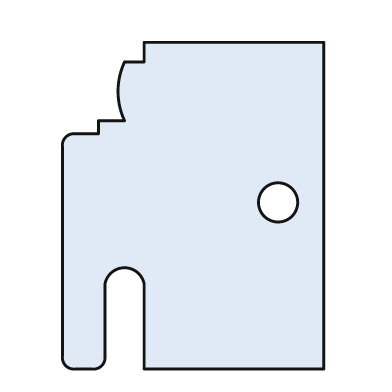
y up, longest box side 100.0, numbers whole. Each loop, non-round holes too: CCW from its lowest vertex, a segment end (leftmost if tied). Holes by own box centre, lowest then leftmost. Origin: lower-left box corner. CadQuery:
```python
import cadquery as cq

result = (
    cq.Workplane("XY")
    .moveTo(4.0, 0.0)
    .lineTo(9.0, 0.0)
    .threePointArc((12.0, 1.0), (13.0, 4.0))
    .lineTo(13.0, 26.0)
    .threePointArc((19.0, 31.0), (25.0, 26.0))
    .lineTo(25.0, 0.0)
    .lineTo(80.0, 0.0)
    .lineTo(80.0, 100.0)
    .lineTo(25.0, 100.0)
    .lineTo(25.0, 94.0)
    .lineTo(19.0, 94.0)
    .threePointArc((17.0, 85.0), (19.0, 76.0))
    .lineTo(11.0, 76.0)
    .lineTo(11.0, 72.0)
    .lineTo(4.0, 72.0)
    .threePointArc((1.0, 71.0), (0.0, 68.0))
    .lineTo(0.0, 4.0)
    .threePointArc((1.0, 1.0), (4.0, 0.0))
    .close()
    .moveTo(66.0, 51.0)
    .circle(6.0)
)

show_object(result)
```